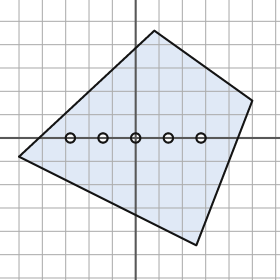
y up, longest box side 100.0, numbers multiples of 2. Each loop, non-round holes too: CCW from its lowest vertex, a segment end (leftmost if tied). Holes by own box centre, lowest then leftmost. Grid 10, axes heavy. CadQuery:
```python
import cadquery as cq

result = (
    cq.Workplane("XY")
    .moveTo(26.0, -46.0)
    .lineTo(50.0, 16.0)
    .lineTo(8.0, 46.0)
    .lineTo(-50.0, -8.0)
    .close()
    .moveTo(-28.0, 0.0)
    .circle(2.0)
    .moveTo(-14.0, 0.0)
    .circle(2.0)
    .moveTo(0.0, 0.0)
    .circle(2.0)
    .moveTo(14.0, 0.0)
    .circle(2.0)
    .moveTo(28.0, 0.0)
    .circle(2.0)
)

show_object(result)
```